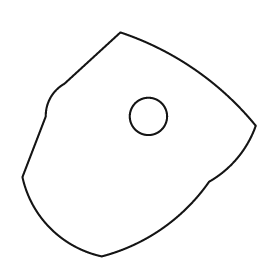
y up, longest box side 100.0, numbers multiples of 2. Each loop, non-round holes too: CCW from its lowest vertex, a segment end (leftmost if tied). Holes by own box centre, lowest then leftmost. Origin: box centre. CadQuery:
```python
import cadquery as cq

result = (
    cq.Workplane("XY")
    .moveTo(-16.0, -48.0)
    .threePointArc((10.0, -36.0), (30.0, -16.0))
    .threePointArc((42.0, -6.0), (50.0, 8.0))
    .threePointArc((24.0, 32.0), (-8.0, 48.0))
    .lineTo(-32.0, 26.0)
    .threePointArc((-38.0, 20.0), (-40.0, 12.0))
    .lineTo(-50.0, -14.0)
    .threePointArc((-38.0, -36.0), (-16.0, -48.0))
    .close()
    .moveTo(4.0, 12.0)
    .circle(8.0)
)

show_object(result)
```